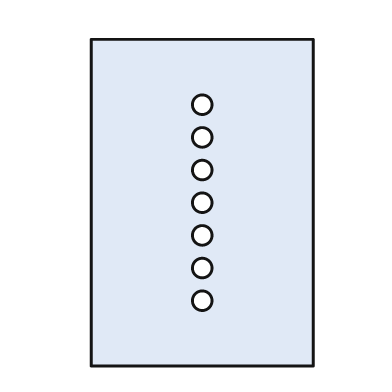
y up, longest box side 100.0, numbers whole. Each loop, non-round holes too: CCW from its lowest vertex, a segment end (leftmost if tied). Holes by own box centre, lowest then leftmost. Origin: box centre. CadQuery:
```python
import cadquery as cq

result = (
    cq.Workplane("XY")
    .moveTo(-34.0, -50.0)
    .lineTo(34.0, -50.0)
    .lineTo(34.0, 50.0)
    .lineTo(-34.0, 50.0)
    .close()
    .moveTo(0.0, -30.0)
    .circle(3.0)
    .moveTo(0.0, -20.0)
    .circle(3.0)
    .moveTo(0.0, -10.0)
    .circle(3.0)
    .moveTo(0.0, 0.0)
    .circle(3.0)
    .moveTo(0.0, 10.0)
    .circle(3.0)
    .moveTo(0.0, 20.0)
    .circle(3.0)
    .moveTo(0.0, 30.0)
    .circle(3.0)
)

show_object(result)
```